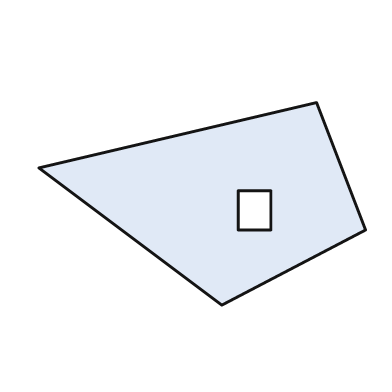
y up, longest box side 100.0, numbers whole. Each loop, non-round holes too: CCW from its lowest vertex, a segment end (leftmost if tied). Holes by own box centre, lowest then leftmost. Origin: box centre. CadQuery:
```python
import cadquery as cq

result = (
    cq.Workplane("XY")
    .moveTo(6.0, -31.0)
    .lineTo(50.0, -8.0)
    .lineTo(35.0, 31.0)
    .lineTo(-50.0, 11.0)
    .close()
    .moveTo(11.0, -8.0)
    .lineTo(21.0, -8.0)
    .lineTo(21.0, 4.0)
    .lineTo(11.0, 4.0)
    .close()
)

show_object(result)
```